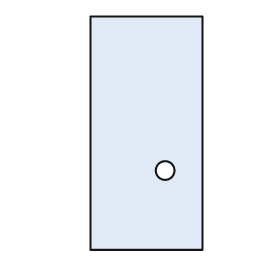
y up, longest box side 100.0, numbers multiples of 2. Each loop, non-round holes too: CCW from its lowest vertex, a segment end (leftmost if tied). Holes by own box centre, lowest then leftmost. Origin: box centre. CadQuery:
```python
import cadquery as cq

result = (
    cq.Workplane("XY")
    .moveTo(-24.0, -50.0)
    .lineTo(24.0, -50.0)
    .lineTo(24.0, 50.0)
    .lineTo(-24.0, 50.0)
    .close()
    .moveTo(8.0, -16.0)
    .circle(4.0)
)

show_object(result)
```